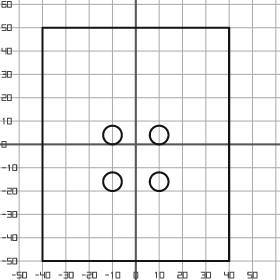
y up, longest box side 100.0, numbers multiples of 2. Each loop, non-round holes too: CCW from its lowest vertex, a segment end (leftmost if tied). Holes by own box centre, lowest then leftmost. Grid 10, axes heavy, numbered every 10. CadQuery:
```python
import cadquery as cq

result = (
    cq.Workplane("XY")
    .moveTo(-40.0, -50.0)
    .lineTo(40.0, -50.0)
    .lineTo(40.0, 50.0)
    .lineTo(-40.0, 50.0)
    .close()
    .moveTo(-10.0, -16.0)
    .circle(4.0)
    .moveTo(10.0, -16.0)
    .circle(4.0)
    .moveTo(-10.0, 4.0)
    .circle(4.0)
    .moveTo(10.0, 4.0)
    .circle(4.0)
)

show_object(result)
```